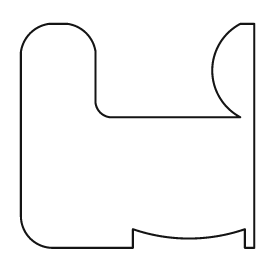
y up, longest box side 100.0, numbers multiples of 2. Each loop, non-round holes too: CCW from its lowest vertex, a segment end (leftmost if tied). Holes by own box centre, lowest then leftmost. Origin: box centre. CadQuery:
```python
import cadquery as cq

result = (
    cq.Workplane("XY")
    .moveTo(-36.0, -48.0)
    .lineTo(-2.0, -48.0)
    .lineTo(-2.0, -40.0)
    .threePointArc((22.0, -44.0), (46.0, -40.0))
    .lineTo(46.0, -48.0)
    .lineTo(50.0, -48.0)
    .lineTo(50.0, 48.0)
    .lineTo(44.0, 48.0)
    .threePointArc((32.0, 28.0), (44.0, 8.0))
    .lineTo(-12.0, 8.0)
    .threePointArc((-16.0, 10.0), (-18.0, 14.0))
    .lineTo(-18.0, 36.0)
    .threePointArc((-22.0, 44.0), (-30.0, 48.0))
    .lineTo(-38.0, 48.0)
    .threePointArc((-46.0, 44.0), (-50.0, 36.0))
    .lineTo(-50.0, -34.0)
    .threePointArc((-46.0, -44.0), (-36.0, -48.0))
    .close()
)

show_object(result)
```